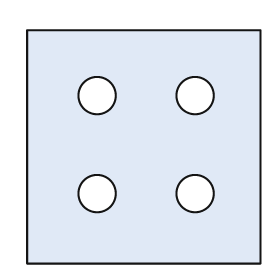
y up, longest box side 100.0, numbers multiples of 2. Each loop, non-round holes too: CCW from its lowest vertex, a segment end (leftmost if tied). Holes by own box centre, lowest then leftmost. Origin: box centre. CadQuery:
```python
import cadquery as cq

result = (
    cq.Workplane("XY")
    .moveTo(-50.0, -50.0)
    .lineTo(50.0, -50.0)
    .lineTo(50.0, 50.0)
    .lineTo(-50.0, 50.0)
    .close()
    .moveTo(-20.0, -20.0)
    .circle(8.0)
    .moveTo(22.0, -20.0)
    .circle(8.0)
    .moveTo(-20.0, 22.0)
    .circle(8.0)
    .moveTo(22.0, 22.0)
    .circle(8.0)
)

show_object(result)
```